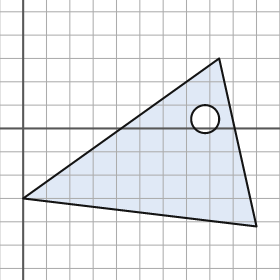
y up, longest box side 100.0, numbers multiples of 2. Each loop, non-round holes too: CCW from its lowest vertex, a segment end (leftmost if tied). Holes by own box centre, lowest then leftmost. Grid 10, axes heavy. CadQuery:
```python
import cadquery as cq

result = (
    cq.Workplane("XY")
    .moveTo(100.0, -42.0)
    .lineTo(84.0, 30.0)
    .lineTo(0.0, -30.0)
    .close()
    .moveTo(78.0, 4.0)
    .circle(6.0)
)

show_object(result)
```